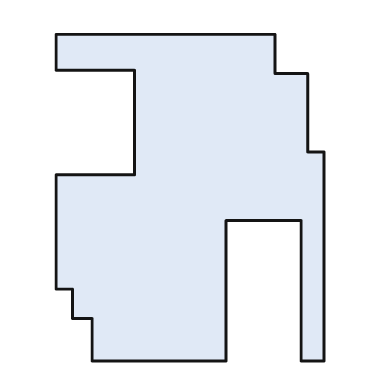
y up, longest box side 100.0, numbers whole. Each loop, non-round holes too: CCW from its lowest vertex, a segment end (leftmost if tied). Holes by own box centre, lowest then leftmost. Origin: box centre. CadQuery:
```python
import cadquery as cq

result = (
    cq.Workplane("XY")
    .moveTo(-30.0, -50.0)
    .lineTo(11.0, -50.0)
    .lineTo(11.0, -7.0)
    .lineTo(34.0, -7.0)
    .lineTo(34.0, -50.0)
    .lineTo(41.0, -50.0)
    .lineTo(41.0, 14.0)
    .lineTo(36.0, 14.0)
    .lineTo(36.0, 38.0)
    .lineTo(26.0, 38.0)
    .lineTo(26.0, 50.0)
    .lineTo(-41.0, 50.0)
    .lineTo(-41.0, 39.0)
    .lineTo(-17.0, 39.0)
    .lineTo(-17.0, 7.0)
    .lineTo(-41.0, 7.0)
    .lineTo(-41.0, -28.0)
    .lineTo(-36.0, -28.0)
    .lineTo(-36.0, -37.0)
    .lineTo(-30.0, -37.0)
    .close()
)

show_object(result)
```